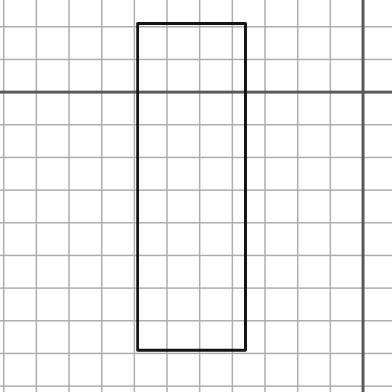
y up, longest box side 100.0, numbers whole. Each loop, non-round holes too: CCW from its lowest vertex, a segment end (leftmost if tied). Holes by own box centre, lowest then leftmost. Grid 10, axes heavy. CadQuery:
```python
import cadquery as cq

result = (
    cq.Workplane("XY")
    .moveTo(-69.0, -79.0)
    .lineTo(-36.0, -79.0)
    .lineTo(-36.0, 21.0)
    .lineTo(-69.0, 21.0)
    .close()
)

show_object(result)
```